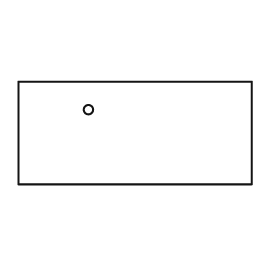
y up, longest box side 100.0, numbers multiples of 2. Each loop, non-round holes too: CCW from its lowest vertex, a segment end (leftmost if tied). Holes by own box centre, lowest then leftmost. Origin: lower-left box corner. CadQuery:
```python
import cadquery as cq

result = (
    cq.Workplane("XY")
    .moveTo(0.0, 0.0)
    .lineTo(100.0, 0.0)
    .lineTo(100.0, 44.0)
    .lineTo(0.0, 44.0)
    .close()
    .moveTo(30.0, 32.0)
    .circle(2.0)
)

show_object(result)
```